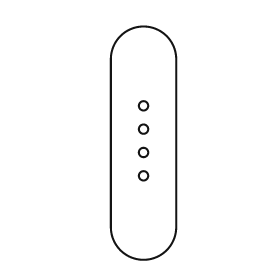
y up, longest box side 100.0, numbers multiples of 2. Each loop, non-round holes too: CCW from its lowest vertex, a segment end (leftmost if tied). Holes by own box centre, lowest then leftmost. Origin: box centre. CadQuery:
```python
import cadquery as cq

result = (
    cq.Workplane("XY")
    .moveTo(-14.0, -36.0)
    .threePointArc((0.0, -50.0), (14.0, -36.0))
    .lineTo(14.0, 36.0)
    .threePointArc((0.0, 50.0), (-14.0, 36.0))
    .close()
    .moveTo(0.0, -14.0)
    .circle(2.0)
    .moveTo(0.0, -4.0)
    .circle(2.0)
    .moveTo(0.0, 6.0)
    .circle(2.0)
    .moveTo(0.0, 16.0)
    .circle(2.0)
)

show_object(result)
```